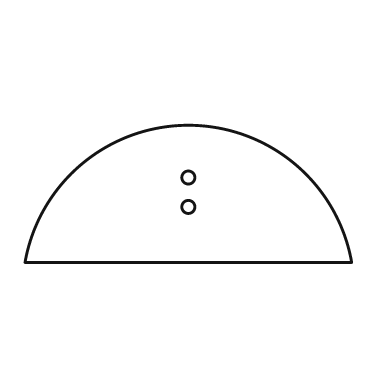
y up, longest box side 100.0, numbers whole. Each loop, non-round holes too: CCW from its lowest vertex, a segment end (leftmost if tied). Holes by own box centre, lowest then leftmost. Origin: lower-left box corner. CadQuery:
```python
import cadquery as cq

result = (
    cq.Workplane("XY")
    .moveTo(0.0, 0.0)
    .lineTo(100.0, 0.0)
    .threePointArc((50.0, 42.0), (0.0, 0.0))
    .close()
    .moveTo(50.0, 17.0)
    .circle(2.0)
    .moveTo(50.0, 26.0)
    .circle(2.0)
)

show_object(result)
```